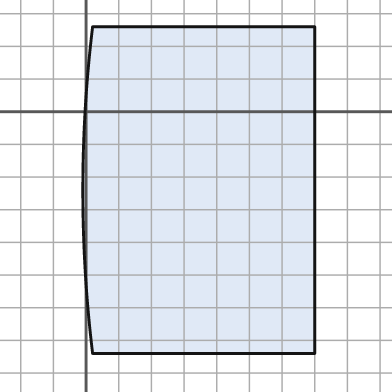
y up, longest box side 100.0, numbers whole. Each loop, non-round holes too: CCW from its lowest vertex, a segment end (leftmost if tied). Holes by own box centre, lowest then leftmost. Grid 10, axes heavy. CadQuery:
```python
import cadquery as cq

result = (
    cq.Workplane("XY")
    .moveTo(2.0, -74.0)
    .lineTo(70.0, -74.0)
    .lineTo(70.0, 26.0)
    .lineTo(2.0, 26.0)
    .threePointArc((-1.0, -24.0), (2.0, -74.0))
    .close()
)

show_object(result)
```